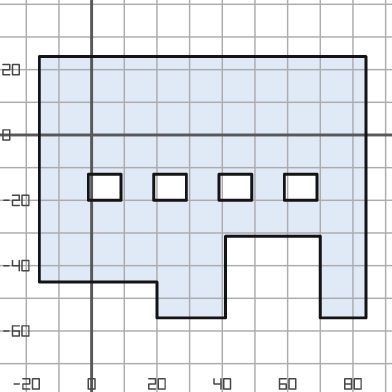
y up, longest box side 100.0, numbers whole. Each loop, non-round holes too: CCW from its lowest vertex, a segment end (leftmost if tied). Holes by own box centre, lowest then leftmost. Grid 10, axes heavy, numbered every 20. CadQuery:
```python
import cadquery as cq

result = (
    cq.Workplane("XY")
    .moveTo(20.0, -56.0)
    .lineTo(41.0, -56.0)
    .lineTo(41.0, -31.0)
    .lineTo(70.0, -31.0)
    .lineTo(70.0, -56.0)
    .lineTo(84.0, -56.0)
    .lineTo(84.0, 24.0)
    .lineTo(-16.0, 24.0)
    .lineTo(-16.0, -45.0)
    .lineTo(20.0, -45.0)
    .close()
    .moveTo(-1.0, -20.0)
    .lineTo(9.0, -20.0)
    .lineTo(9.0, -12.0)
    .lineTo(-1.0, -12.0)
    .close()
    .moveTo(19.0, -20.0)
    .lineTo(29.0, -20.0)
    .lineTo(29.0, -12.0)
    .lineTo(19.0, -12.0)
    .close()
    .moveTo(39.0, -20.0)
    .lineTo(49.0, -20.0)
    .lineTo(49.0, -12.0)
    .lineTo(39.0, -12.0)
    .close()
    .moveTo(59.0, -20.0)
    .lineTo(69.0, -20.0)
    .lineTo(69.0, -12.0)
    .lineTo(59.0, -12.0)
    .close()
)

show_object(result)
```